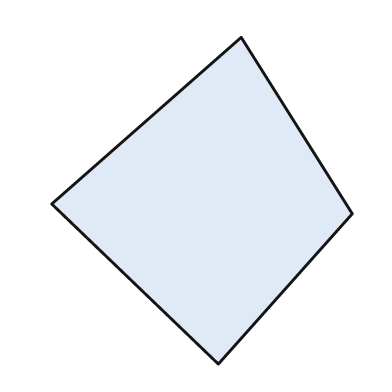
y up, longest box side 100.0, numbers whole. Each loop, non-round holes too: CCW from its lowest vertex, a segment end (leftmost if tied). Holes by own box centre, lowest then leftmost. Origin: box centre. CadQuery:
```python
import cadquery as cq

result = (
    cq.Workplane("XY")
    .moveTo(5.0, -50.0)
    .lineTo(46.0, -4.0)
    .lineTo(12.0, 50.0)
    .lineTo(-46.0, -1.0)
    .close()
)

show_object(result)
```